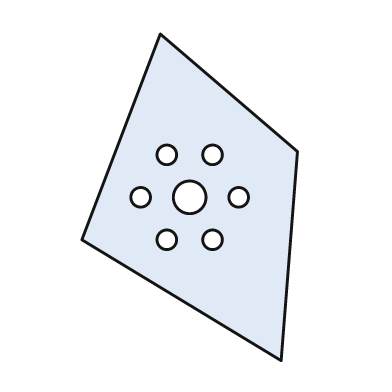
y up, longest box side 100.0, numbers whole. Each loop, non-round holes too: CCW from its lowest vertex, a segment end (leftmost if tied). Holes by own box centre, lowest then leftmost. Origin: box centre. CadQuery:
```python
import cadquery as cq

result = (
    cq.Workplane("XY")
    .moveTo(28.0, -50.0)
    .lineTo(33.0, 14.0)
    .lineTo(-9.0, 50.0)
    .lineTo(-33.0, -13.0)
    .close()
    .moveTo(-7.0, -13.0)
    .circle(3.0)
    .moveTo(7.0, -13.0)
    .circle(3.0)
    .moveTo(-15.0, 0.0)
    .circle(3.0)
    .moveTo(0.0, 0.0)
    .circle(5.0)
    .moveTo(15.0, 0.0)
    .circle(3.0)
    .moveTo(-7.0, 13.0)
    .circle(3.0)
    .moveTo(7.0, 13.0)
    .circle(3.0)
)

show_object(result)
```